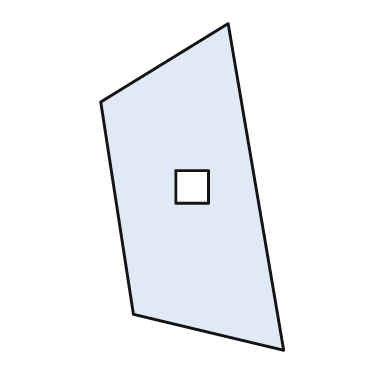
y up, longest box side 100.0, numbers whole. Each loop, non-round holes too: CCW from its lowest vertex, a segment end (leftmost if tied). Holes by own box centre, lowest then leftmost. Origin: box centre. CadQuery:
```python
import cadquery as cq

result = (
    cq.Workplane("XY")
    .moveTo(28.0, -50.0)
    .lineTo(11.0, 50.0)
    .lineTo(-28.0, 26.0)
    .lineTo(-18.0, -39.0)
    .close()
    .moveTo(-5.0, -5.0)
    .lineTo(5.0, -5.0)
    .lineTo(5.0, 5.0)
    .lineTo(-5.0, 5.0)
    .close()
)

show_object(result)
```